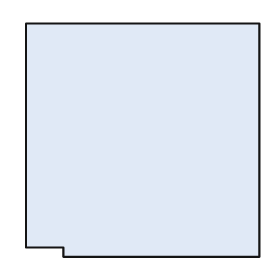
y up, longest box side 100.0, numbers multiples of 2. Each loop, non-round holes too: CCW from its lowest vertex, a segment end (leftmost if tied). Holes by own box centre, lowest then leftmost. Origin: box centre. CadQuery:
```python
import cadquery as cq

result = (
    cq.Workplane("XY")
    .moveTo(-34.0, -50.0)
    .lineTo(50.0, -50.0)
    .lineTo(50.0, 50.0)
    .lineTo(-50.0, 50.0)
    .lineTo(-50.0, -46.0)
    .lineTo(-34.0, -46.0)
    .close()
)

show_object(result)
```